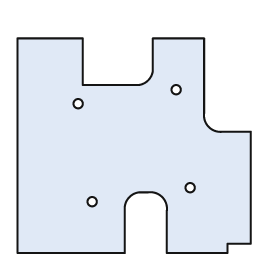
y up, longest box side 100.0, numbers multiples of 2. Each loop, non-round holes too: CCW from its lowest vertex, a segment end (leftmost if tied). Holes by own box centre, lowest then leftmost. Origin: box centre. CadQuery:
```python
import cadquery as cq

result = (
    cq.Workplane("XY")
    .moveTo(-50.0, -46.0)
    .lineTo(-4.0, -46.0)
    .lineTo(-4.0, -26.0)
    .threePointArc((-2.0, -22.0), (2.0, -20.0))
    .lineTo(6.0, -20.0)
    .threePointArc((12.0, -22.0), (14.0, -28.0))
    .lineTo(14.0, -46.0)
    .lineTo(40.0, -46.0)
    .lineTo(40.0, -42.0)
    .lineTo(50.0, -42.0)
    .lineTo(50.0, 6.0)
    .lineTo(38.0, 6.0)
    .threePointArc((32.0, 8.0), (30.0, 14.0))
    .lineTo(30.0, 46.0)
    .lineTo(8.0, 46.0)
    .lineTo(8.0, 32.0)
    .threePointArc((6.0, 28.0), (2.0, 26.0))
    .lineTo(-22.0, 26.0)
    .lineTo(-22.0, 46.0)
    .lineTo(-50.0, 46.0)
    .close()
    .moveTo(-18.0, -24.0)
    .circle(2.0)
    .moveTo(24.0, -18.0)
    .circle(2.0)
    .moveTo(-24.0, 18.0)
    .circle(2.0)
    .moveTo(18.0, 24.0)
    .circle(2.0)
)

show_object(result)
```